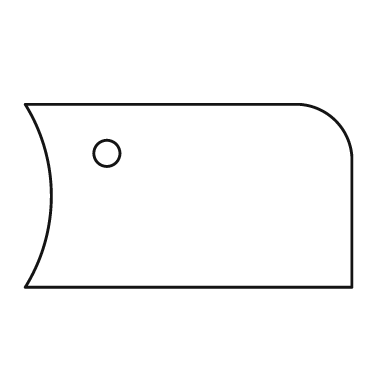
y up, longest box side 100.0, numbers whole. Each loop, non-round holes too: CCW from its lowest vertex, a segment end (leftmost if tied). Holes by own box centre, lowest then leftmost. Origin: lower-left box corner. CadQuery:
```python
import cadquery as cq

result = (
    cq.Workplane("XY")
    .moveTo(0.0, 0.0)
    .lineTo(100.0, 0.0)
    .lineTo(100.0, 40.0)
    .threePointArc((95.0, 51.0), (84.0, 56.0))
    .lineTo(0.0, 56.0)
    .threePointArc((8.0, 28.0), (0.0, 0.0))
    .close()
    .moveTo(25.0, 41.0)
    .circle(4.0)
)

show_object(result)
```